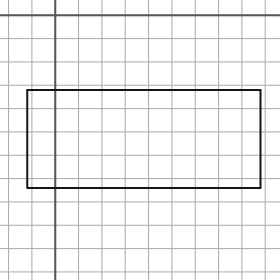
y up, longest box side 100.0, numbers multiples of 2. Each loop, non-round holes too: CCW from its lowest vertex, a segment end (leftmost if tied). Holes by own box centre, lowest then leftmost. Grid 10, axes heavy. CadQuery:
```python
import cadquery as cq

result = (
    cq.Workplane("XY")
    .moveTo(-12.0, -74.0)
    .lineTo(88.0, -74.0)
    .lineTo(88.0, -32.0)
    .lineTo(-12.0, -32.0)
    .close()
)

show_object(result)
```